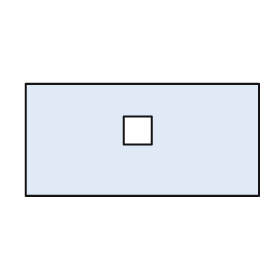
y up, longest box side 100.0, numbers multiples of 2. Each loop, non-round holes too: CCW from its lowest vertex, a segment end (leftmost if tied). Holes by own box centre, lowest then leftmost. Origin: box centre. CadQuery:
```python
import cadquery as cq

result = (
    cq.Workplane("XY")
    .moveTo(-50.0, -24.0)
    .lineTo(50.0, -24.0)
    .lineTo(50.0, 24.0)
    .lineTo(-50.0, 24.0)
    .close()
    .moveTo(-8.0, -2.0)
    .lineTo(4.0, -2.0)
    .lineTo(4.0, 10.0)
    .lineTo(-8.0, 10.0)
    .close()
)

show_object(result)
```